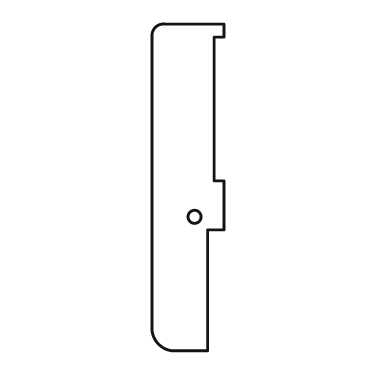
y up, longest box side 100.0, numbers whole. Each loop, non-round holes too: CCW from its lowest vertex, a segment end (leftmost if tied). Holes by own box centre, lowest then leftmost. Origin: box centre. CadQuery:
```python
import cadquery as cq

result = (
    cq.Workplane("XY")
    .moveTo(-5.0, -50.0)
    .lineTo(6.0, -50.0)
    .lineTo(6.0, -13.0)
    .lineTo(11.0, -13.0)
    .lineTo(11.0, 2.0)
    .lineTo(8.0, 2.0)
    .lineTo(8.0, 46.0)
    .lineTo(11.0, 46.0)
    .lineTo(11.0, 50.0)
    .lineTo(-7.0, 50.0)
    .threePointArc((-10.0, 49.0), (-11.0, 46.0))
    .lineTo(-11.0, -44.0)
    .threePointArc((-9.0, -48.0), (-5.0, -50.0))
    .close()
    .moveTo(2.0, -9.0)
    .circle(2.0)
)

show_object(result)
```